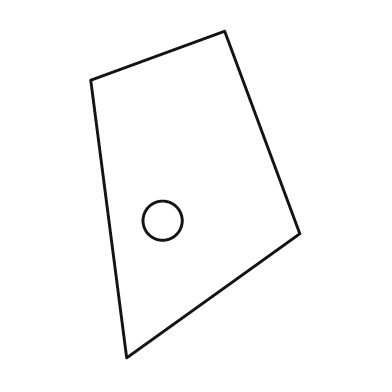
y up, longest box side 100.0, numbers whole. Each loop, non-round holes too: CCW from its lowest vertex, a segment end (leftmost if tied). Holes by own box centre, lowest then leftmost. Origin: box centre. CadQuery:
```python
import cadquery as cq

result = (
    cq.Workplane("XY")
    .moveTo(-21.0, -50.0)
    .lineTo(32.0, -12.0)
    .lineTo(9.0, 50.0)
    .lineTo(-32.0, 35.0)
    .close()
    .moveTo(-10.0, -8.0)
    .circle(6.0)
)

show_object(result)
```